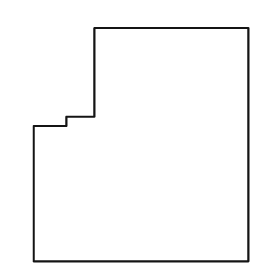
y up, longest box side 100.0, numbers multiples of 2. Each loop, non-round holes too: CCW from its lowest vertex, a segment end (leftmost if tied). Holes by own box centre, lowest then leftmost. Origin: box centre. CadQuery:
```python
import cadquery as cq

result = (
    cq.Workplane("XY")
    .moveTo(-46.0, -50.0)
    .lineTo(46.0, -50.0)
    .lineTo(46.0, 50.0)
    .lineTo(-20.0, 50.0)
    .lineTo(-20.0, 12.0)
    .lineTo(-32.0, 12.0)
    .lineTo(-32.0, 8.0)
    .lineTo(-46.0, 8.0)
    .close()
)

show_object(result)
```